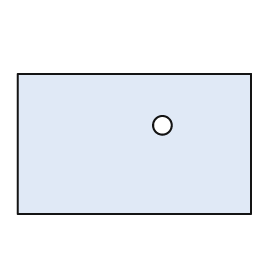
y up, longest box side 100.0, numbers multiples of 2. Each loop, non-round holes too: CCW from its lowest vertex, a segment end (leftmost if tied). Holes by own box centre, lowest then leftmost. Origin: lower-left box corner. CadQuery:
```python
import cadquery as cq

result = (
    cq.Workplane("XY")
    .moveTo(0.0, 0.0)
    .lineTo(100.0, 0.0)
    .lineTo(100.0, 60.0)
    .lineTo(0.0, 60.0)
    .close()
    .moveTo(62.0, 38.0)
    .circle(4.0)
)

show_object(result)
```